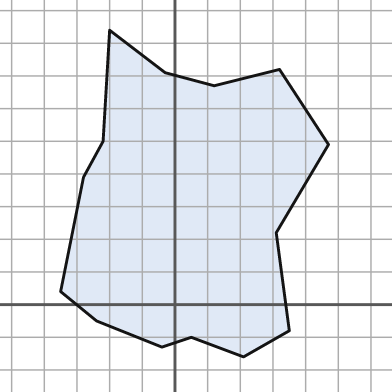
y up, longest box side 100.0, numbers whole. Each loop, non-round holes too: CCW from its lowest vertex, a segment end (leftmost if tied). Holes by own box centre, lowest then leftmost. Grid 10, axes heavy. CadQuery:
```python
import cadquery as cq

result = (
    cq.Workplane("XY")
    .moveTo(21.0, -16.0)
    .lineTo(35.0, -8.0)
    .lineTo(31.0, 22.0)
    .lineTo(47.0, 49.0)
    .lineTo(32.0, 72.0)
    .lineTo(12.0, 67.0)
    .lineTo(-3.0, 71.0)
    .lineTo(-20.0, 84.0)
    .lineTo(-22.0, 50.0)
    .lineTo(-28.0, 39.0)
    .lineTo(-35.0, 4.0)
    .lineTo(-24.0, -5.0)
    .lineTo(-4.0, -13.0)
    .lineTo(5.0, -10.0)
    .close()
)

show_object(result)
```